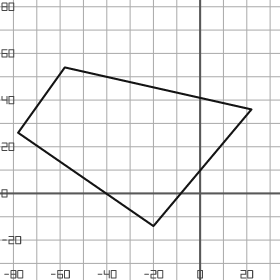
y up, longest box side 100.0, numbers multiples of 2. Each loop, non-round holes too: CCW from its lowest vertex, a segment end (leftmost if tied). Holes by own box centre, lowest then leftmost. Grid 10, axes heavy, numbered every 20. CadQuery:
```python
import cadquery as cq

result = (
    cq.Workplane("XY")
    .moveTo(-20.0, -14.0)
    .lineTo(22.0, 36.0)
    .lineTo(-58.0, 54.0)
    .lineTo(-78.0, 26.0)
    .close()
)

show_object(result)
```